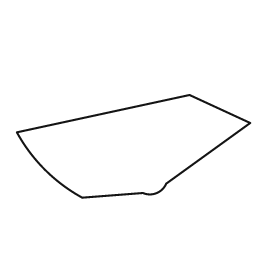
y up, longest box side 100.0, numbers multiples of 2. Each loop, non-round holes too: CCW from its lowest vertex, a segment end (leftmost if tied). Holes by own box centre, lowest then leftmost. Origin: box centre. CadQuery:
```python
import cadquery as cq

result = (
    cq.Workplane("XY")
    .moveTo(-22.0, -22.0)
    .lineTo(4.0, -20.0)
    .threePointArc((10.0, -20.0), (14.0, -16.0))
    .lineTo(50.0, 10.0)
    .lineTo(24.0, 22.0)
    .lineTo(-50.0, 6.0)
    .threePointArc((-38.0, -10.0), (-22.0, -22.0))
    .close()
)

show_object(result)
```